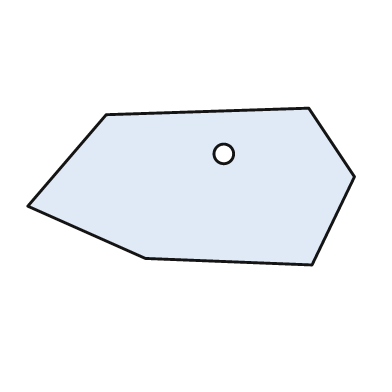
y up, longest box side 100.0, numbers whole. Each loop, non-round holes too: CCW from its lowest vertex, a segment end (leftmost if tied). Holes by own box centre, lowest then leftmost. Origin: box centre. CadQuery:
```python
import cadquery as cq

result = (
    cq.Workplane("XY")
    .moveTo(37.0, -24.0)
    .lineTo(50.0, 3.0)
    .lineTo(36.0, 24.0)
    .lineTo(-26.0, 22.0)
    .lineTo(-50.0, -6.0)
    .lineTo(-14.0, -22.0)
    .close()
    .moveTo(10.0, 10.0)
    .circle(3.0)
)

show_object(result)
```